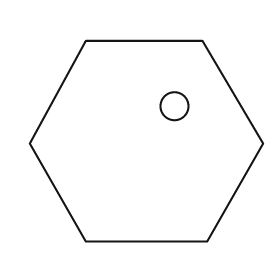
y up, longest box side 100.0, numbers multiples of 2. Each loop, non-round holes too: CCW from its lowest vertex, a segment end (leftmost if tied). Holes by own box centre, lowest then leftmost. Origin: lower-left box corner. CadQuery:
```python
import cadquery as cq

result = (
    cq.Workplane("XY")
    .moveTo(24.0, 0.0)
    .lineTo(76.0, 0.0)
    .lineTo(100.0, 42.0)
    .lineTo(74.0, 86.0)
    .lineTo(24.0, 86.0)
    .lineTo(0.0, 42.0)
    .close()
    .moveTo(62.0, 58.0)
    .circle(6.0)
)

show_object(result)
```